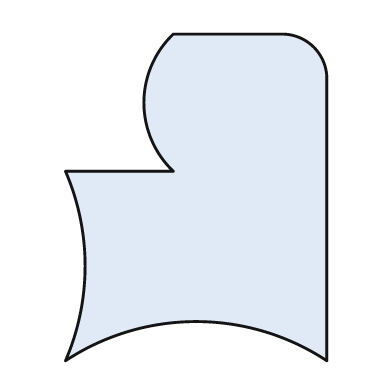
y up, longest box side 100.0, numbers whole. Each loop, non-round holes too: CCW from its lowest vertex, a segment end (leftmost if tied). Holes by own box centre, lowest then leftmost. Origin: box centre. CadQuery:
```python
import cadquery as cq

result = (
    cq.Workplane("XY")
    .moveTo(-40.0, -50.0)
    .threePointArc((0.0, -38.0), (40.0, -50.0))
    .lineTo(40.0, 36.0)
    .threePointArc((36.0, 46.0), (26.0, 50.0))
    .lineTo(-7.0, 50.0)
    .threePointArc((-16.0, 29.0), (-7.0, 8.0))
    .lineTo(-40.0, 8.0)
    .threePointArc((-34.0, -21.0), (-40.0, -50.0))
    .close()
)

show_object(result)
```